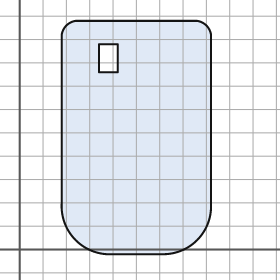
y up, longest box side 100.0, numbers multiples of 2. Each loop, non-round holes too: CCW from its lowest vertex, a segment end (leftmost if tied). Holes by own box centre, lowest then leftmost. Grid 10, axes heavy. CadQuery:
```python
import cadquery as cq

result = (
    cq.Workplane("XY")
    .moveTo(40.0, -2.0)
    .lineTo(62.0, -2.0)
    .threePointArc((76.0, 4.0), (82.0, 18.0))
    .lineTo(82.0, 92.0)
    .threePointArc((80.0, 96.0), (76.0, 98.0))
    .lineTo(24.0, 98.0)
    .threePointArc((20.0, 96.0), (18.0, 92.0))
    .lineTo(18.0, 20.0)
    .threePointArc((24.0, 4.0), (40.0, -2.0))
    .close()
    .moveTo(34.0, 76.0)
    .lineTo(42.0, 76.0)
    .lineTo(42.0, 88.0)
    .lineTo(34.0, 88.0)
    .close()
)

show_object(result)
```